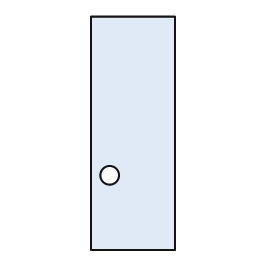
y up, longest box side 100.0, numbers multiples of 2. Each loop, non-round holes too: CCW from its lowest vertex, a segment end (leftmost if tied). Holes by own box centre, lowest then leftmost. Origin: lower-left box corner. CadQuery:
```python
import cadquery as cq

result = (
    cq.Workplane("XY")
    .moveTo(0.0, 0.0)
    .lineTo(36.0, 0.0)
    .lineTo(36.0, 100.0)
    .lineTo(0.0, 100.0)
    .close()
    .moveTo(8.0, 32.0)
    .circle(4.0)
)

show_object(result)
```